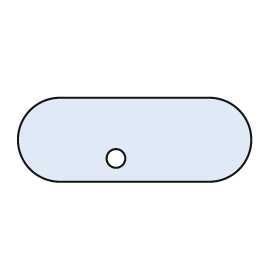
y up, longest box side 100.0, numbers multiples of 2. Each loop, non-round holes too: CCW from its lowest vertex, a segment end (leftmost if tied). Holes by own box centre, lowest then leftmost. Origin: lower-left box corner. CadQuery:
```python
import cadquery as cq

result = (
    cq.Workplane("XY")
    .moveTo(18.0, 0.0)
    .lineTo(82.0, 0.0)
    .threePointArc((100.0, 18.0), (82.0, 36.0))
    .lineTo(18.0, 36.0)
    .threePointArc((0.0, 18.0), (18.0, 0.0))
    .close()
    .moveTo(42.0, 10.0)
    .circle(4.0)
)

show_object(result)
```